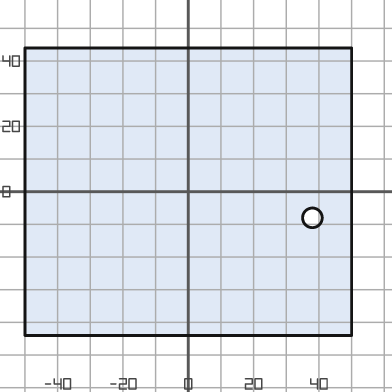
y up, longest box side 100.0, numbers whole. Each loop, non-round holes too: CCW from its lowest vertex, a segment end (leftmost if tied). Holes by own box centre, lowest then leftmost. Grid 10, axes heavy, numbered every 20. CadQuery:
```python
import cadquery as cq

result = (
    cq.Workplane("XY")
    .moveTo(-50.0, -44.0)
    .lineTo(50.0, -44.0)
    .lineTo(50.0, 44.0)
    .lineTo(-50.0, 44.0)
    .close()
    .moveTo(38.0, -8.0)
    .circle(3.0)
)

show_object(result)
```